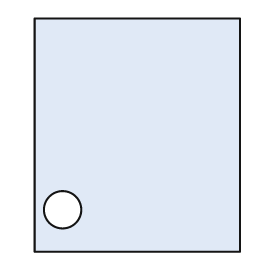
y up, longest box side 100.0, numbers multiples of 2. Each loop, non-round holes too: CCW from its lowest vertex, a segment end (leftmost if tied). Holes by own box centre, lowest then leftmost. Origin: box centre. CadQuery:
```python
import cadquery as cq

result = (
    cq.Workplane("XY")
    .moveTo(-44.0, -50.0)
    .lineTo(44.0, -50.0)
    .lineTo(44.0, 50.0)
    .lineTo(-44.0, 50.0)
    .close()
    .moveTo(-32.0, -32.0)
    .circle(8.0)
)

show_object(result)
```